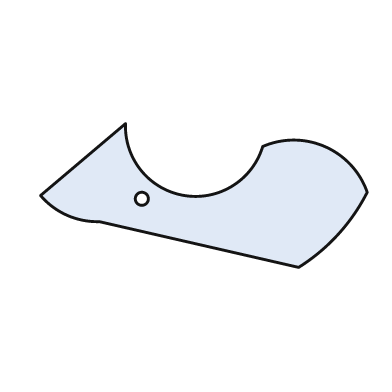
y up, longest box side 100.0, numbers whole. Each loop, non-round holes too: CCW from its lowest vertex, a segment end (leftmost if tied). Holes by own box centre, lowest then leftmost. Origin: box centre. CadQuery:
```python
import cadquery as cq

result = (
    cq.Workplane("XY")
    .moveTo(29.0, -22.0)
    .threePointArc((41.0, -12.0), (50.0, 1.0))
    .threePointArc((37.0, 15.0), (18.0, 15.0))
    .threePointArc((-6.0, 0.0), (-24.0, 22.0))
    .lineTo(-50.0, 0.0)
    .threePointArc((-42.0, -6.0), (-32.0, -8.0))
    .close()
    .moveTo(-19.0, -1.0)
    .circle(2.0)
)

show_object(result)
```